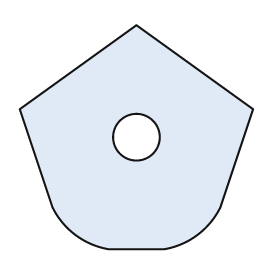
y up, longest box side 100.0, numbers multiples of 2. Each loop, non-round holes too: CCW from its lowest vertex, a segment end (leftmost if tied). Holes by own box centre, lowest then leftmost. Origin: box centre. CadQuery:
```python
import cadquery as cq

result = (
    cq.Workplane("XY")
    .moveTo(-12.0, -48.0)
    .lineTo(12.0, -48.0)
    .threePointArc((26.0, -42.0), (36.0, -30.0))
    .lineTo(50.0, 12.0)
    .lineTo(0.0, 48.0)
    .lineTo(-50.0, 12.0)
    .lineTo(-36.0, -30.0)
    .threePointArc((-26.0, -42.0), (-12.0, -48.0))
    .close()
    .moveTo(0.0, 0.0)
    .circle(10.0)
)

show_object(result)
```